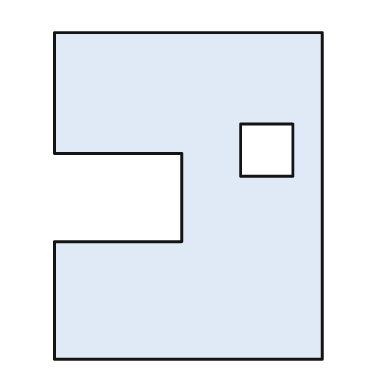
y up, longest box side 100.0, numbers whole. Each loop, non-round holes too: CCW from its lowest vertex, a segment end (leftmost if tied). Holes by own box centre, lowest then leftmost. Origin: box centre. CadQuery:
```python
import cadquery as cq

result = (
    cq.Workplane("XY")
    .moveTo(-41.0, -50.0)
    .lineTo(41.0, -50.0)
    .lineTo(41.0, 50.0)
    .lineTo(-41.0, 50.0)
    .lineTo(-41.0, 13.0)
    .lineTo(-2.0, 13.0)
    .lineTo(-2.0, -14.0)
    .lineTo(-41.0, -14.0)
    .close()
    .moveTo(16.0, 6.0)
    .lineTo(32.0, 6.0)
    .lineTo(32.0, 22.0)
    .lineTo(16.0, 22.0)
    .close()
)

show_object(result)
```